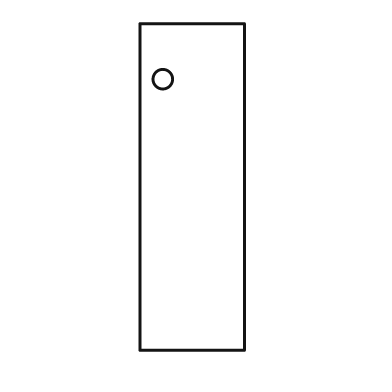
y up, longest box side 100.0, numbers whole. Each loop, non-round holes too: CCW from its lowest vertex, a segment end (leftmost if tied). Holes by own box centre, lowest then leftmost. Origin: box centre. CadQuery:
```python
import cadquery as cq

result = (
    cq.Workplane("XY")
    .moveTo(-16.0, -50.0)
    .lineTo(16.0, -50.0)
    .lineTo(16.0, 50.0)
    .lineTo(-16.0, 50.0)
    .close()
    .moveTo(-9.0, 33.0)
    .circle(3.0)
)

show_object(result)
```